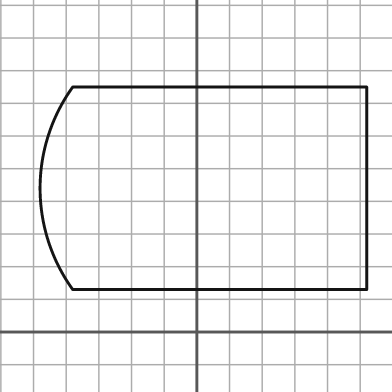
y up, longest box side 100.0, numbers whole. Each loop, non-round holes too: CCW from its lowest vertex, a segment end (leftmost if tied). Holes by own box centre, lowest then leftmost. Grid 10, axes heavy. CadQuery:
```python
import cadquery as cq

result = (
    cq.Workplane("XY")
    .moveTo(-38.0, 13.0)
    .lineTo(52.0, 13.0)
    .lineTo(52.0, 75.0)
    .lineTo(-38.0, 75.0)
    .threePointArc((-48.0, 44.0), (-38.0, 13.0))
    .close()
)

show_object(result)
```